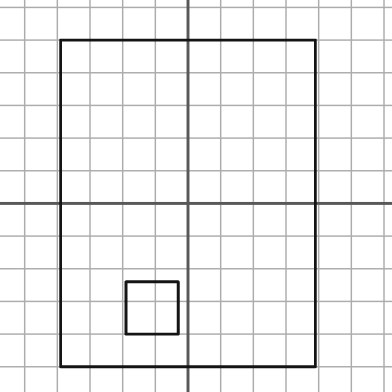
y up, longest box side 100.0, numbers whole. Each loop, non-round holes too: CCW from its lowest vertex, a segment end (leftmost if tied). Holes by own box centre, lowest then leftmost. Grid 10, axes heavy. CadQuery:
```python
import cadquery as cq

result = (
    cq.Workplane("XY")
    .moveTo(-39.0, -50.0)
    .lineTo(39.0, -50.0)
    .lineTo(39.0, 50.0)
    .lineTo(-39.0, 50.0)
    .close()
    .moveTo(-19.0, -40.0)
    .lineTo(-3.0, -40.0)
    .lineTo(-3.0, -24.0)
    .lineTo(-19.0, -24.0)
    .close()
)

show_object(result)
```